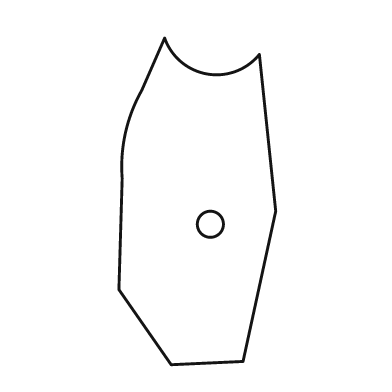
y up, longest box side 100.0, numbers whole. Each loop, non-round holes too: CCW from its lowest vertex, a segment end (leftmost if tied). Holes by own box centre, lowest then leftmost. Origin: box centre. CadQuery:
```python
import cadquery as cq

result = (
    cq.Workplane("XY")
    .moveTo(-8.0, -50.0)
    .lineTo(14.0, -49.0)
    .lineTo(24.0, -3.0)
    .lineTo(19.0, 45.0)
    .threePointArc((3.0, 39.0), (-10.0, 50.0))
    .lineTo(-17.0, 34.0)
    .threePointArc((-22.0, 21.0), (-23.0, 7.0))
    .lineTo(-24.0, -27.0)
    .close()
    .moveTo(4.0, -7.0)
    .circle(4.0)
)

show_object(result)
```